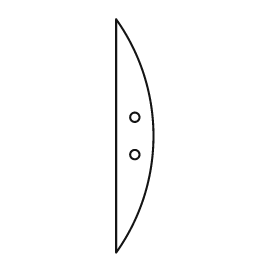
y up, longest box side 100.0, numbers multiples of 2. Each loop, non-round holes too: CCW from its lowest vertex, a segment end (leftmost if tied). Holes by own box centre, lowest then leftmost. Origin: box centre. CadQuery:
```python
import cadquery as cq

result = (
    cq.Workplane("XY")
    .moveTo(-8.0, -50.0)
    .threePointArc((8.0, 0.0), (-8.0, 50.0))
    .close()
    .moveTo(0.0, -8.0)
    .circle(2.0)
    .moveTo(0.0, 8.0)
    .circle(2.0)
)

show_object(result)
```